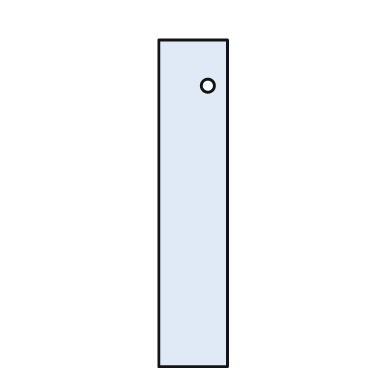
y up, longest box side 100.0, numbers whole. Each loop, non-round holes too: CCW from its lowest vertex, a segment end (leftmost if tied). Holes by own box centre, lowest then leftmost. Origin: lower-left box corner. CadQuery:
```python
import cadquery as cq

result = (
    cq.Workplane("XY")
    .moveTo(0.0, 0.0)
    .lineTo(21.0, 0.0)
    .lineTo(21.0, 100.0)
    .lineTo(0.0, 100.0)
    .close()
    .moveTo(15.0, 86.0)
    .circle(2.0)
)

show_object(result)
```